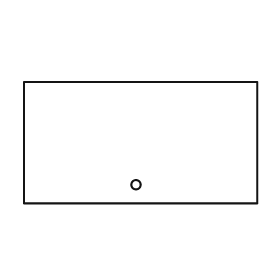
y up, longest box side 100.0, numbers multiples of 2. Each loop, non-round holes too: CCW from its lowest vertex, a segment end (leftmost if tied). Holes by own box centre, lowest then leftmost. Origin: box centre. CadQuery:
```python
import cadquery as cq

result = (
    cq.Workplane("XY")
    .moveTo(-50.0, -26.0)
    .lineTo(50.0, -26.0)
    .lineTo(50.0, 26.0)
    .lineTo(-50.0, 26.0)
    .close()
    .moveTo(-2.0, -18.0)
    .circle(2.0)
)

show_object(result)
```